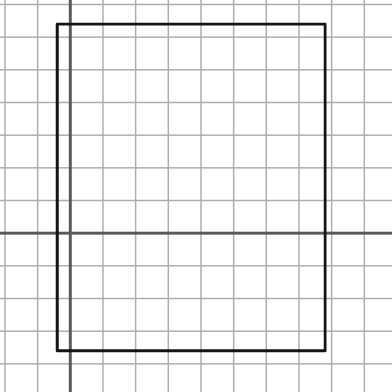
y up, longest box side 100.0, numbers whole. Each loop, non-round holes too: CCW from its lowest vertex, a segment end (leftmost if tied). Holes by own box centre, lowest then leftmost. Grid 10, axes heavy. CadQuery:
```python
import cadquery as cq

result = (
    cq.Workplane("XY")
    .moveTo(-4.0, -36.0)
    .lineTo(78.0, -36.0)
    .lineTo(78.0, 64.0)
    .lineTo(-4.0, 64.0)
    .close()
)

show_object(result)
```